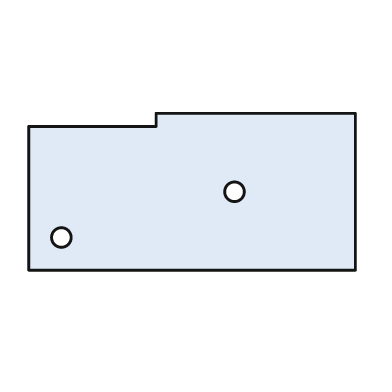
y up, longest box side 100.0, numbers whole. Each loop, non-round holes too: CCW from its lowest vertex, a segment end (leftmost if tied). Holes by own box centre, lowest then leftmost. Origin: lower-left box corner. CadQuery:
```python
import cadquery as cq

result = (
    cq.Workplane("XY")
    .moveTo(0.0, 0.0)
    .lineTo(100.0, 0.0)
    .lineTo(100.0, 48.0)
    .lineTo(39.0, 48.0)
    .lineTo(39.0, 44.0)
    .lineTo(0.0, 44.0)
    .close()
    .moveTo(10.0, 10.0)
    .circle(3.0)
    .moveTo(63.0, 24.0)
    .circle(3.0)
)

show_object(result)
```